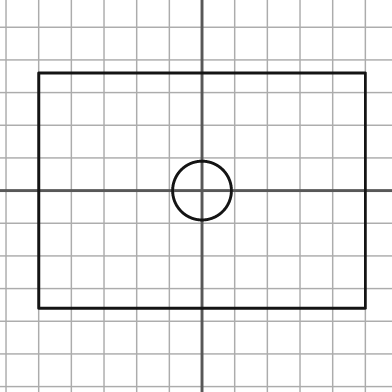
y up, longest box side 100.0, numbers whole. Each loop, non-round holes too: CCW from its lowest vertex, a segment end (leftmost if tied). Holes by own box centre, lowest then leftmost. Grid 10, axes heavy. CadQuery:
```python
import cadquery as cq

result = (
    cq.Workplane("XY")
    .moveTo(-50.0, -36.0)
    .lineTo(50.0, -36.0)
    .lineTo(50.0, 36.0)
    .lineTo(-50.0, 36.0)
    .close()
    .moveTo(0.0, 0.0)
    .circle(9.0)
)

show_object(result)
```